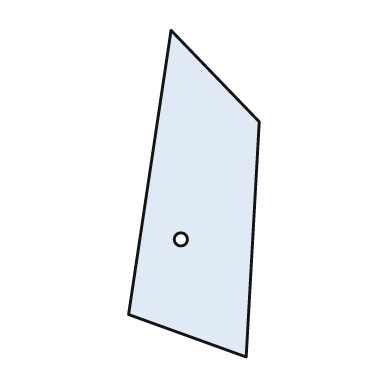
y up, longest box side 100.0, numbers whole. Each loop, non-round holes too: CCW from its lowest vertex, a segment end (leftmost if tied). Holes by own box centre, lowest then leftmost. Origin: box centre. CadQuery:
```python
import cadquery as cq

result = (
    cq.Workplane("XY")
    .moveTo(16.0, -50.0)
    .lineTo(20.0, 22.0)
    .lineTo(-7.0, 50.0)
    .lineTo(-20.0, -37.0)
    .close()
    .moveTo(-4.0, -14.0)
    .circle(2.0)
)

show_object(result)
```